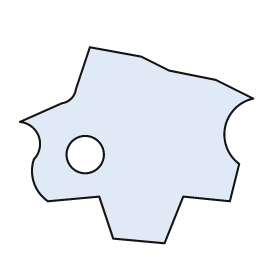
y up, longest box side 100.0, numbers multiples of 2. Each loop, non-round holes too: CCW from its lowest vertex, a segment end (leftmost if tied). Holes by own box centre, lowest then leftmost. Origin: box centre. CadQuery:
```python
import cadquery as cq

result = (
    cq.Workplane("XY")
    .moveTo(12.0, -42.0)
    .lineTo(20.0, -22.0)
    .lineTo(40.0, -24.0)
    .lineTo(44.0, -8.0)
    .threePointArc((38.0, 8.0), (50.0, 20.0))
    .lineTo(34.0, 28.0)
    .lineTo(14.0, 32.0)
    .lineTo(2.0, 38.0)
    .lineTo(-20.0, 42.0)
    .lineTo(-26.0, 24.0)
    .threePointArc((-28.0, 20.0), (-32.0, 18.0))
    .lineTo(-50.0, 10.0)
    .threePointArc((-42.0, 4.0), (-44.0, -6.0))
    .threePointArc((-44.0, -16.0), (-38.0, -24.0))
    .lineTo(-16.0, -22.0)
    .lineTo(-10.0, -40.0)
    .close()
    .moveTo(-22.0, -4.0)
    .circle(8.0)
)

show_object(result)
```